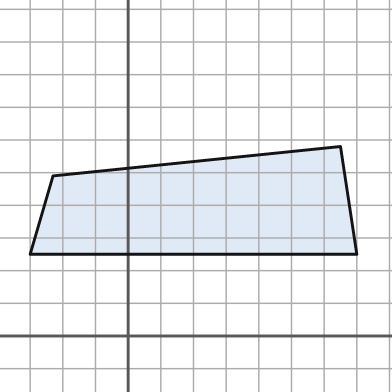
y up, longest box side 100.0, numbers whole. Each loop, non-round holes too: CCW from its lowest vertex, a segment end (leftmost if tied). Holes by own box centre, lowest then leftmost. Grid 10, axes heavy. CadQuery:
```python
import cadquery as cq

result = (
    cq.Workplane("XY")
    .moveTo(-30.0, 25.0)
    .lineTo(70.0, 25.0)
    .lineTo(65.0, 58.0)
    .lineTo(-23.0, 49.0)
    .close()
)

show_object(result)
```